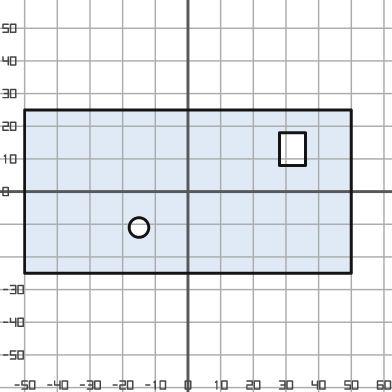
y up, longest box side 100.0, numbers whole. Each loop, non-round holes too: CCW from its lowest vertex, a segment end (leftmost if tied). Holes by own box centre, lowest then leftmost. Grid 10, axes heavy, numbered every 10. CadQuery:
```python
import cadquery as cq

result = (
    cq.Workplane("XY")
    .moveTo(-50.0, -25.0)
    .lineTo(50.0, -25.0)
    .lineTo(50.0, 25.0)
    .lineTo(-50.0, 25.0)
    .close()
    .moveTo(-15.0, -11.0)
    .circle(3.0)
    .moveTo(28.0, 8.0)
    .lineTo(36.0, 8.0)
    .lineTo(36.0, 18.0)
    .lineTo(28.0, 18.0)
    .close()
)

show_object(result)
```